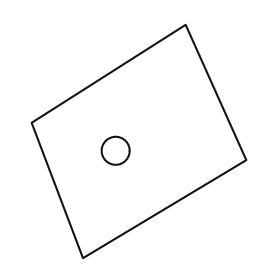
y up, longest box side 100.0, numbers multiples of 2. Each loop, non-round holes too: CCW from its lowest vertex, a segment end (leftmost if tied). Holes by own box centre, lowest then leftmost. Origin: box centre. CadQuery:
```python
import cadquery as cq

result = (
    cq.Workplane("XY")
    .moveTo(-24.0, -50.0)
    .lineTo(46.0, -8.0)
    .lineTo(20.0, 50.0)
    .lineTo(-46.0, 8.0)
    .close()
    .moveTo(-10.0, -4.0)
    .circle(6.0)
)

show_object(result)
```